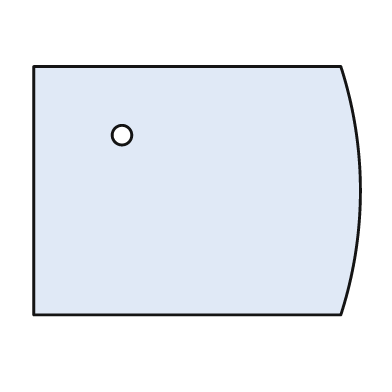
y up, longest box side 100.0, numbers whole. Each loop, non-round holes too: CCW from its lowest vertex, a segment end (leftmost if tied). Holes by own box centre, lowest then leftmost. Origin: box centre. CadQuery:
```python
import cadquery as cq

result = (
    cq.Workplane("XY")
    .moveTo(-50.0, -38.0)
    .lineTo(44.0, -38.0)
    .threePointArc((50.0, 0.0), (44.0, 38.0))
    .lineTo(-50.0, 38.0)
    .close()
    .moveTo(-23.0, 17.0)
    .circle(3.0)
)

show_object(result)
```